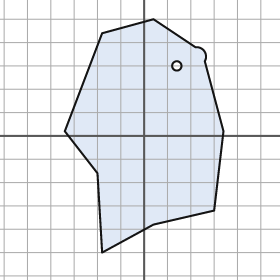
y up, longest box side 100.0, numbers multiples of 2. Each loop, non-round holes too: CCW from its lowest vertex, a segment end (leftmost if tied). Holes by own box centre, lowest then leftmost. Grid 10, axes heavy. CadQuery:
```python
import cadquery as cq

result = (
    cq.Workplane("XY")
    .moveTo(-18.0, -50.0)
    .lineTo(4.0, -38.0)
    .lineTo(30.0, -32.0)
    .lineTo(34.0, 2.0)
    .lineTo(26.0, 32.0)
    .threePointArc((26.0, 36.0), (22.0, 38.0))
    .lineTo(4.0, 50.0)
    .lineTo(-18.0, 44.0)
    .lineTo(-34.0, 2.0)
    .lineTo(-20.0, -16.0)
    .close()
    .moveTo(14.0, 30.0)
    .circle(2.0)
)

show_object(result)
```